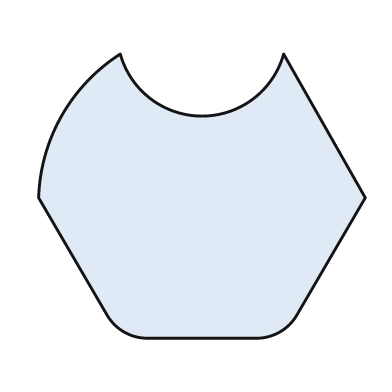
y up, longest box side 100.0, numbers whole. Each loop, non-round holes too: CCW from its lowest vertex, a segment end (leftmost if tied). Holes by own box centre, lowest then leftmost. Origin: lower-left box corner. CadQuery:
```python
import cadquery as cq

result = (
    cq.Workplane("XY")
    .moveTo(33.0, 0.0)
    .lineTo(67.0, 0.0)
    .threePointArc((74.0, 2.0), (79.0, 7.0))
    .lineTo(100.0, 43.0)
    .lineTo(75.0, 87.0)
    .threePointArc((50.0, 68.0), (25.0, 87.0))
    .threePointArc((7.0, 68.0), (0.0, 43.0))
    .lineTo(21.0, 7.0)
    .threePointArc((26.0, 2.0), (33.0, 0.0))
    .close()
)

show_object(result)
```